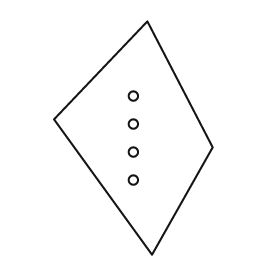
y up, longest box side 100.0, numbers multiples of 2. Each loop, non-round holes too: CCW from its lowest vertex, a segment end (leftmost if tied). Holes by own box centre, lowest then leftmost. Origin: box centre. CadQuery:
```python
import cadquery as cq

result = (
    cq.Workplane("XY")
    .moveTo(8.0, -50.0)
    .lineTo(34.0, -4.0)
    .lineTo(6.0, 50.0)
    .lineTo(-34.0, 8.0)
    .close()
    .moveTo(0.0, -18.0)
    .circle(2.0)
    .moveTo(0.0, -6.0)
    .circle(2.0)
    .moveTo(0.0, 6.0)
    .circle(2.0)
    .moveTo(0.0, 18.0)
    .circle(2.0)
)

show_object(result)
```